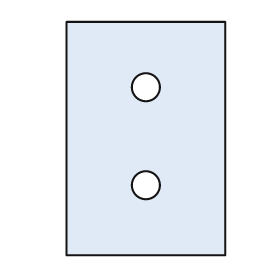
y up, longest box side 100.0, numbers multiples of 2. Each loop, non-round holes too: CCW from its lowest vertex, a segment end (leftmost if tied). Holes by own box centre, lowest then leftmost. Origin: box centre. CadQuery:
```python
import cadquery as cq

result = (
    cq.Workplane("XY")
    .moveTo(-34.0, -50.0)
    .lineTo(34.0, -50.0)
    .lineTo(34.0, 50.0)
    .lineTo(-34.0, 50.0)
    .close()
    .moveTo(0.0, -20.0)
    .circle(6.0)
    .moveTo(0.0, 22.0)
    .circle(6.0)
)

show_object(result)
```